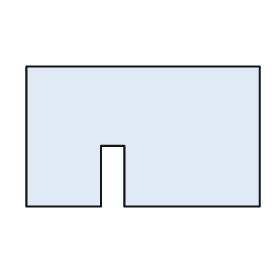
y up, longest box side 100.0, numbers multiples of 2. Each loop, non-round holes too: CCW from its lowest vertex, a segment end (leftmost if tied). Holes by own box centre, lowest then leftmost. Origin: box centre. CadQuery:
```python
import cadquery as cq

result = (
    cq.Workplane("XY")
    .moveTo(-50.0, -30.0)
    .lineTo(-18.0, -30.0)
    .lineTo(-18.0, -4.0)
    .lineTo(-8.0, -4.0)
    .lineTo(-8.0, -30.0)
    .lineTo(50.0, -30.0)
    .lineTo(50.0, 30.0)
    .lineTo(-50.0, 30.0)
    .close()
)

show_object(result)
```